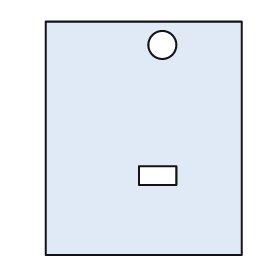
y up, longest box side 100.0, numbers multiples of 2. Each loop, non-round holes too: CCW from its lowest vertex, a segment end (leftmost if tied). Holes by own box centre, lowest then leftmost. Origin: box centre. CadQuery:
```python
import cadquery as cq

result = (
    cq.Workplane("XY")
    .moveTo(-42.0, -50.0)
    .lineTo(42.0, -50.0)
    .lineTo(42.0, 50.0)
    .lineTo(-42.0, 50.0)
    .close()
    .moveTo(-2.0, -20.0)
    .lineTo(14.0, -20.0)
    .lineTo(14.0, -12.0)
    .lineTo(-2.0, -12.0)
    .close()
    .moveTo(8.0, 40.0)
    .circle(6.0)
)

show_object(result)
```